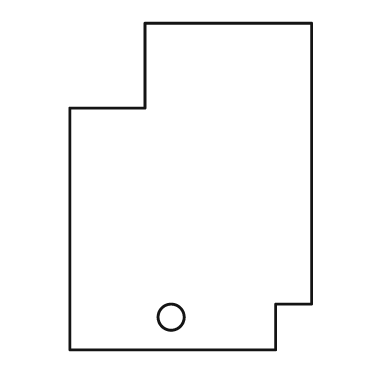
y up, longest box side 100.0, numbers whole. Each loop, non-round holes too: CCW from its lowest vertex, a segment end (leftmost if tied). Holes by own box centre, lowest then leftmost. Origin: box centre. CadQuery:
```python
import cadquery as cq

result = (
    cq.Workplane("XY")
    .moveTo(-37.0, -50.0)
    .lineTo(26.0, -50.0)
    .lineTo(26.0, -36.0)
    .lineTo(37.0, -36.0)
    .lineTo(37.0, 50.0)
    .lineTo(-14.0, 50.0)
    .lineTo(-14.0, 24.0)
    .lineTo(-37.0, 24.0)
    .close()
    .moveTo(-6.0, -40.0)
    .circle(4.0)
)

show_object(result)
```